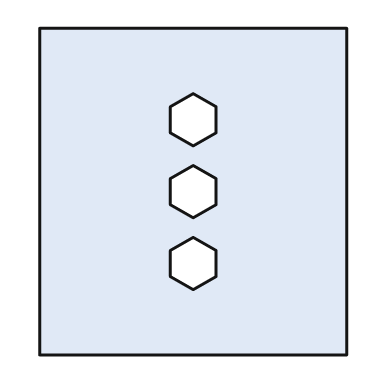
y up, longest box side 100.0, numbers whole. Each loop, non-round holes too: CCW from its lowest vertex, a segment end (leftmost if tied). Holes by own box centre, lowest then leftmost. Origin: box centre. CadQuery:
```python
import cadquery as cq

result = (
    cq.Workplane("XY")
    .moveTo(-47.0, -50.0)
    .lineTo(47.0, -50.0)
    .lineTo(47.0, 50.0)
    .lineTo(-47.0, 50.0)
    .close()
    .moveTo(0.0, -30.0)
    .lineTo(7.0, -26.0)
    .lineTo(7.0, -18.0)
    .lineTo(0.0, -14.0)
    .lineTo(-7.0, -18.0)
    .lineTo(-7.0, -26.0)
    .close()
    .moveTo(0.0, -8.0)
    .lineTo(7.0, -4.0)
    .lineTo(7.0, 4.0)
    .lineTo(0.0, 8.0)
    .lineTo(-7.0, 4.0)
    .lineTo(-7.0, -4.0)
    .close()
    .moveTo(0.0, 14.0)
    .lineTo(7.0, 18.0)
    .lineTo(7.0, 26.0)
    .lineTo(0.0, 30.0)
    .lineTo(-7.0, 26.0)
    .lineTo(-7.0, 18.0)
    .close()
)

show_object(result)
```